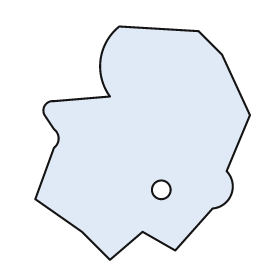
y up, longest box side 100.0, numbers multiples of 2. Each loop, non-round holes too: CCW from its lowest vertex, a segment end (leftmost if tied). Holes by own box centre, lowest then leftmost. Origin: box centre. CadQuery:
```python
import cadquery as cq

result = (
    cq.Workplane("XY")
    .moveTo(-14.0, -50.0)
    .lineTo(0.0, -38.0)
    .lineTo(14.0, -46.0)
    .lineTo(30.0, -28.0)
    .threePointArc((38.0, -22.0), (36.0, -12.0))
    .lineTo(46.0, 12.0)
    .lineTo(34.0, 38.0)
    .lineTo(24.0, 48.0)
    .lineTo(-10.0, 50.0)
    .threePointArc((-18.0, 36.0), (-14.0, 20.0))
    .lineTo(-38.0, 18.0)
    .threePointArc((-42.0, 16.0), (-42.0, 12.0))
    .lineTo(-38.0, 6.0)
    .threePointArc((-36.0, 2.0), (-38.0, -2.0))
    .lineTo(-46.0, -24.0)
    .lineTo(-26.0, -38.0)
    .close()
    .moveTo(8.0, -20.0)
    .circle(4.0)
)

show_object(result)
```